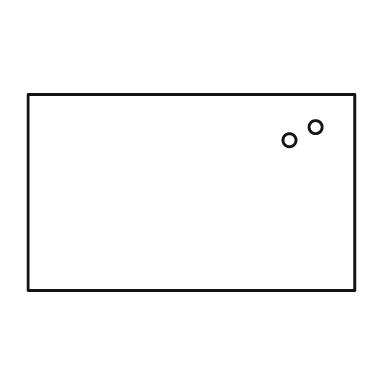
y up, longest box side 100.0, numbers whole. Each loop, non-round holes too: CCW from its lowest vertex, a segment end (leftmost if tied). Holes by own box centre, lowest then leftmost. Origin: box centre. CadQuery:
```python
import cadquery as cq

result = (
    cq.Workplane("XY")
    .moveTo(-50.0, -30.0)
    .lineTo(50.0, -30.0)
    .lineTo(50.0, 30.0)
    .lineTo(-50.0, 30.0)
    .close()
    .moveTo(30.0, 16.0)
    .circle(2.0)
    .moveTo(38.0, 20.0)
    .circle(2.0)
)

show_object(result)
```